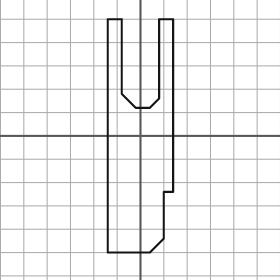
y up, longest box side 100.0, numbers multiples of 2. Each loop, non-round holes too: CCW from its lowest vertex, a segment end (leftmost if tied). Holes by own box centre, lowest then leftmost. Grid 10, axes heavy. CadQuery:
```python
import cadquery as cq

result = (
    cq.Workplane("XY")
    .moveTo(-14.0, -50.0)
    .lineTo(4.0, -50.0)
    .lineTo(10.0, -44.0)
    .lineTo(10.0, -24.0)
    .lineTo(14.0, -24.0)
    .lineTo(14.0, 50.0)
    .lineTo(8.0, 50.0)
    .lineTo(8.0, 16.0)
    .lineTo(4.0, 12.0)
    .lineTo(-2.0, 12.0)
    .lineTo(-8.0, 18.0)
    .lineTo(-8.0, 50.0)
    .lineTo(-14.0, 50.0)
    .close()
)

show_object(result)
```